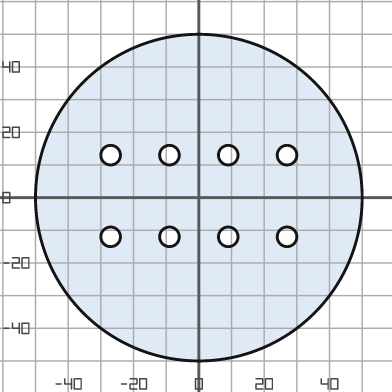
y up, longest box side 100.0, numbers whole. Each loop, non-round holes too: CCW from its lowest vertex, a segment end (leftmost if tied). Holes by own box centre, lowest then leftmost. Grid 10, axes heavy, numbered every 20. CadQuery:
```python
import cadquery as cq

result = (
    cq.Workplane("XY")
    .moveTo(0.0, 0.0)
    .circle(50.0)
    .moveTo(-27.0, -12.0)
    .circle(3.0)
    .moveTo(-9.0, -12.0)
    .circle(3.0)
    .moveTo(9.0, -12.0)
    .circle(3.0)
    .moveTo(27.0, -12.0)
    .circle(3.0)
    .moveTo(-27.0, 13.0)
    .circle(3.0)
    .moveTo(-9.0, 13.0)
    .circle(3.0)
    .moveTo(9.0, 13.0)
    .circle(3.0)
    .moveTo(27.0, 13.0)
    .circle(3.0)
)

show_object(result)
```